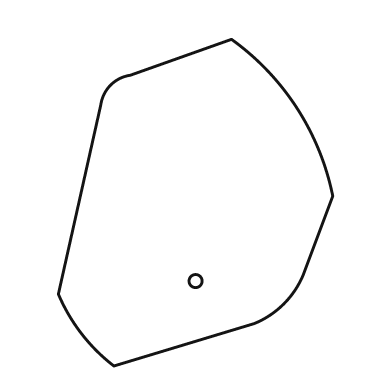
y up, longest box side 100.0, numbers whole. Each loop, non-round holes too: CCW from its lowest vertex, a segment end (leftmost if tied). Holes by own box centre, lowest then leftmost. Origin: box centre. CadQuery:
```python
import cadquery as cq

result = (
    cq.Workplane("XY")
    .moveTo(-25.0, -50.0)
    .lineTo(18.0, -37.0)
    .threePointArc((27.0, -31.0), (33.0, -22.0))
    .lineTo(42.0, 2.0)
    .threePointArc((31.0, 29.0), (11.0, 50.0))
    .lineTo(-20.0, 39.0)
    .threePointArc((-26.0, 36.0), (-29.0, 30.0))
    .lineTo(-42.0, -28.0)
    .threePointArc((-35.0, -40.0), (-25.0, -50.0))
    .close()
    .moveTo(0.0, -24.0)
    .circle(2.0)
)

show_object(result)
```